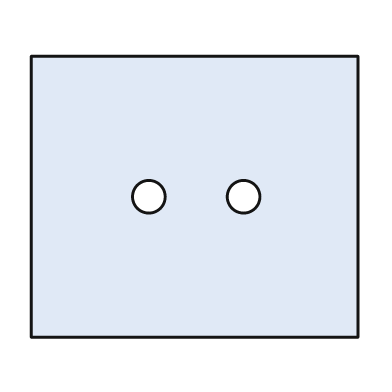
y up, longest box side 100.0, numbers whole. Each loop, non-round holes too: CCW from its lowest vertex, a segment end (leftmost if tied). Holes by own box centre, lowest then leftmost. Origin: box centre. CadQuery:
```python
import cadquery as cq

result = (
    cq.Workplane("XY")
    .moveTo(-50.0, -43.0)
    .lineTo(50.0, -43.0)
    .lineTo(50.0, 43.0)
    .lineTo(-50.0, 43.0)
    .close()
    .moveTo(-14.0, 0.0)
    .circle(5.0)
    .moveTo(15.0, 0.0)
    .circle(5.0)
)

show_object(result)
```